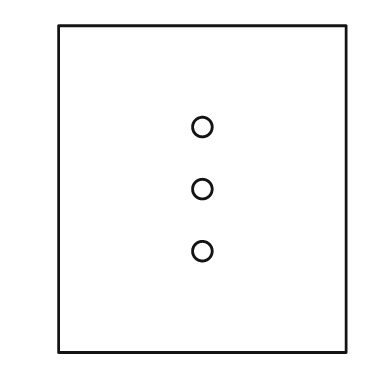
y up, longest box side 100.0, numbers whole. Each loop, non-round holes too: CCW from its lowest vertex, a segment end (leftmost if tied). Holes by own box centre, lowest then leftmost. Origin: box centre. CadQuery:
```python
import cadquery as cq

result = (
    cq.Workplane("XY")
    .moveTo(-44.0, -50.0)
    .lineTo(44.0, -50.0)
    .lineTo(44.0, 50.0)
    .lineTo(-44.0, 50.0)
    .close()
    .moveTo(0.0, -19.0)
    .circle(3.0)
    .moveTo(0.0, 0.0)
    .circle(3.0)
    .moveTo(0.0, 19.0)
    .circle(3.0)
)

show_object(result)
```